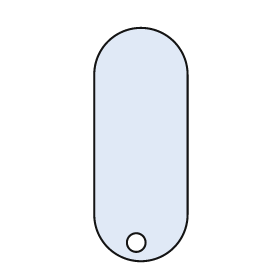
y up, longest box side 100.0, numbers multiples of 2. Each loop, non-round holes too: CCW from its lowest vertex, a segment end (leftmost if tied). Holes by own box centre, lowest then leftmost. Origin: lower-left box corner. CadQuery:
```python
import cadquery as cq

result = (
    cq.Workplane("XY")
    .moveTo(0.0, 20.0)
    .threePointArc((20.0, 0.0), (40.0, 20.0))
    .lineTo(40.0, 80.0)
    .threePointArc((20.0, 100.0), (0.0, 80.0))
    .close()
    .moveTo(18.0, 8.0)
    .circle(4.0)
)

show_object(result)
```